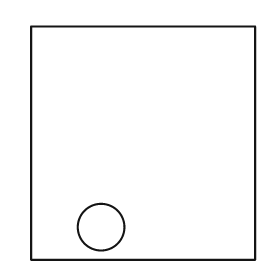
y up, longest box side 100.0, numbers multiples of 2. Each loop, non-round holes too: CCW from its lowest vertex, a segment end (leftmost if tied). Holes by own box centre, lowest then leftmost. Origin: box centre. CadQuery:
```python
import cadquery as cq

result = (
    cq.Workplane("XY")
    .moveTo(-48.0, -50.0)
    .lineTo(48.0, -50.0)
    .lineTo(48.0, 50.0)
    .lineTo(-48.0, 50.0)
    .close()
    .moveTo(-18.0, -36.0)
    .circle(10.0)
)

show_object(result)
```